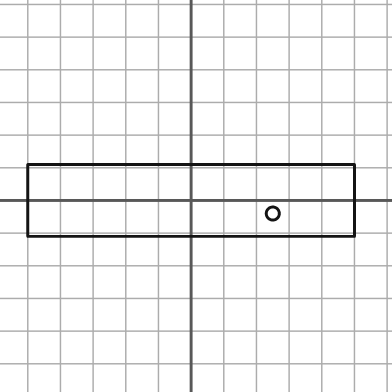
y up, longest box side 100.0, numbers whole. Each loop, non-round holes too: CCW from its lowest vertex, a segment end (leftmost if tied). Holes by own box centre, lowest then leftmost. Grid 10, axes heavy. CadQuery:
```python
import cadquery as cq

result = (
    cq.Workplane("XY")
    .moveTo(-50.0, -11.0)
    .lineTo(50.0, -11.0)
    .lineTo(50.0, 11.0)
    .lineTo(-50.0, 11.0)
    .close()
    .moveTo(25.0, -4.0)
    .circle(2.0)
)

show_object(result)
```